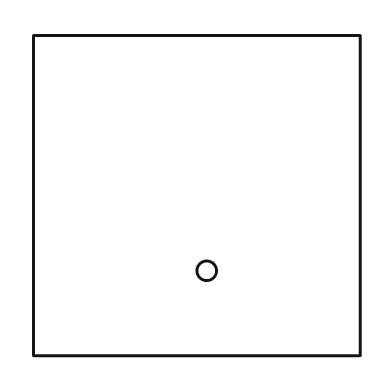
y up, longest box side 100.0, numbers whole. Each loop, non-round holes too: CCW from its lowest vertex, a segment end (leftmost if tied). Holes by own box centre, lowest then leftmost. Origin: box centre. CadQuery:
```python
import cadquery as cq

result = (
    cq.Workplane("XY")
    .moveTo(-50.0, -49.0)
    .lineTo(50.0, -49.0)
    .lineTo(50.0, 49.0)
    .lineTo(-50.0, 49.0)
    .close()
    .moveTo(3.0, -23.0)
    .circle(3.0)
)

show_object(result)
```